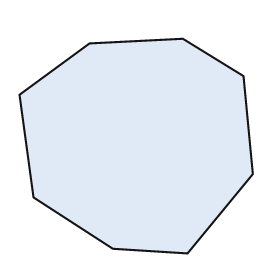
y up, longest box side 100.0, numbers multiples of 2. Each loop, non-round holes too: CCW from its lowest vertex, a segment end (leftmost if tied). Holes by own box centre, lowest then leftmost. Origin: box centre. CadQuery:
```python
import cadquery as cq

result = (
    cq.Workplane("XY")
    .moveTo(22.0, -46.0)
    .lineTo(50.0, -12.0)
    .lineTo(46.0, 30.0)
    .lineTo(20.0, 46.0)
    .lineTo(-20.0, 44.0)
    .lineTo(-50.0, 22.0)
    .lineTo(-44.0, -22.0)
    .lineTo(-10.0, -44.0)
    .close()
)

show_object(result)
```